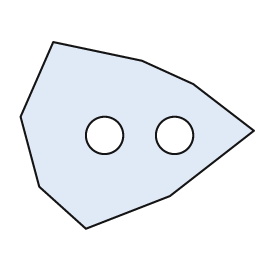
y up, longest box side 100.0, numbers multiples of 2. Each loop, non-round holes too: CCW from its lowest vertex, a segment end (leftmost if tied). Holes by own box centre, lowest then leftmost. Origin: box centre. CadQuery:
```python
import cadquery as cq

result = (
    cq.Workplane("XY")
    .moveTo(-22.0, -40.0)
    .lineTo(14.0, -26.0)
    .lineTo(50.0, 2.0)
    .lineTo(24.0, 22.0)
    .lineTo(2.0, 32.0)
    .lineTo(-36.0, 40.0)
    .lineTo(-50.0, 8.0)
    .lineTo(-42.0, -22.0)
    .close()
    .moveTo(-14.0, 0.0)
    .circle(8.0)
    .moveTo(16.0, 0.0)
    .circle(8.0)
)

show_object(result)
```